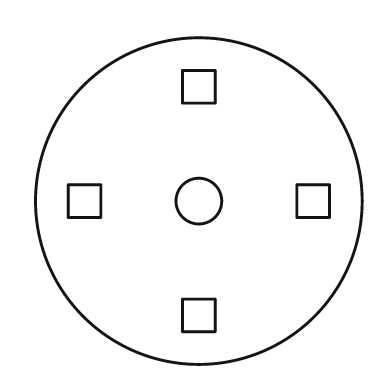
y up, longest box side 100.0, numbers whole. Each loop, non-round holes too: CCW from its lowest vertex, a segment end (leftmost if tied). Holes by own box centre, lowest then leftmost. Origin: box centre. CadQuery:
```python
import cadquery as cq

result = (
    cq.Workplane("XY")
    .moveTo(0.0, 0.0)
    .circle(50.0)
    .moveTo(-5.0, -40.0)
    .lineTo(5.0, -40.0)
    .lineTo(5.0, -30.0)
    .lineTo(-5.0, -30.0)
    .close()
    .moveTo(-40.0, -5.0)
    .lineTo(-30.0, -5.0)
    .lineTo(-30.0, 5.0)
    .lineTo(-40.0, 5.0)
    .close()
    .moveTo(0.0, 0.0)
    .circle(7.0)
    .moveTo(30.0, -5.0)
    .lineTo(40.0, -5.0)
    .lineTo(40.0, 5.0)
    .lineTo(30.0, 5.0)
    .close()
    .moveTo(-5.0, 30.0)
    .lineTo(5.0, 30.0)
    .lineTo(5.0, 40.0)
    .lineTo(-5.0, 40.0)
    .close()
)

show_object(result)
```